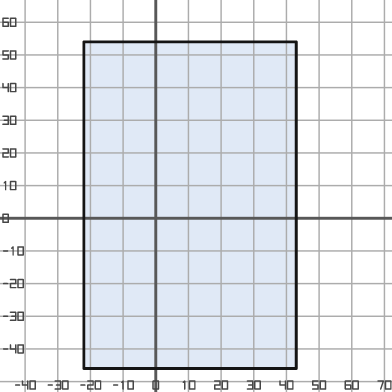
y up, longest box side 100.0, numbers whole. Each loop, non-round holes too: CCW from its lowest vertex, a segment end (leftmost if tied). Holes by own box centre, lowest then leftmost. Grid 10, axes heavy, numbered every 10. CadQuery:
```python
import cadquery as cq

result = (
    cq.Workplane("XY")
    .moveTo(-22.0, -46.0)
    .lineTo(43.0, -46.0)
    .lineTo(43.0, 54.0)
    .lineTo(-22.0, 54.0)
    .close()
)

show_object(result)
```